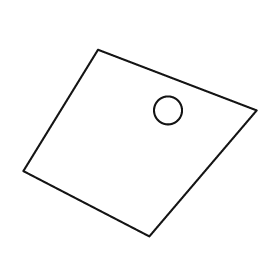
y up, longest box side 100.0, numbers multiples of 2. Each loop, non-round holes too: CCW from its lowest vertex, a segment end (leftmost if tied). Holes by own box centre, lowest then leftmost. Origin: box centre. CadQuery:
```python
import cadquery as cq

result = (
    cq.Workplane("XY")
    .moveTo(4.0, -40.0)
    .lineTo(50.0, 14.0)
    .lineTo(-18.0, 40.0)
    .lineTo(-50.0, -12.0)
    .close()
    .moveTo(12.0, 14.0)
    .circle(6.0)
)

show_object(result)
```